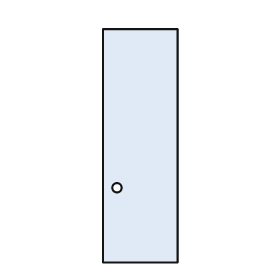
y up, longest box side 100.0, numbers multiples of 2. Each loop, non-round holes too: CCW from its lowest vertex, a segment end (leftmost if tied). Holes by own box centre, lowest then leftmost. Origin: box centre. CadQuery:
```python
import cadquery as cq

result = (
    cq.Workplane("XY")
    .moveTo(-16.0, -50.0)
    .lineTo(16.0, -50.0)
    .lineTo(16.0, 50.0)
    .lineTo(-16.0, 50.0)
    .close()
    .moveTo(-10.0, -18.0)
    .circle(2.0)
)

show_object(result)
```